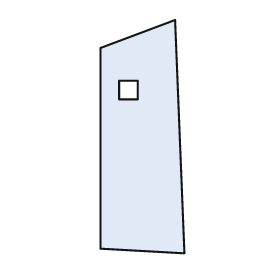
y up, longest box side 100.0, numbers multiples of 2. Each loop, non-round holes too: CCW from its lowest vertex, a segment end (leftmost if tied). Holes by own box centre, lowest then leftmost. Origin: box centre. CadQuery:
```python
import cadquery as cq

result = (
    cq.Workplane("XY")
    .moveTo(18.0, -50.0)
    .lineTo(14.0, 50.0)
    .lineTo(-18.0, 38.0)
    .lineTo(-18.0, -48.0)
    .close()
    .moveTo(-10.0, 16.0)
    .lineTo(-2.0, 16.0)
    .lineTo(-2.0, 24.0)
    .lineTo(-10.0, 24.0)
    .close()
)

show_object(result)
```